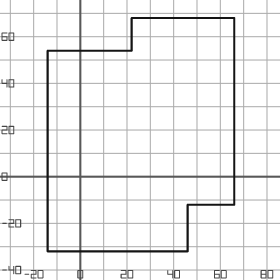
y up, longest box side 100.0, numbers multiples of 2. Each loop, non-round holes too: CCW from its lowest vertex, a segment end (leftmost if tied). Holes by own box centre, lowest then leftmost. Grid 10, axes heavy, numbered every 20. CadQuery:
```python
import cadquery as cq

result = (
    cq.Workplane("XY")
    .moveTo(-14.0, -32.0)
    .lineTo(46.0, -32.0)
    .lineTo(46.0, -12.0)
    .lineTo(66.0, -12.0)
    .lineTo(66.0, 68.0)
    .lineTo(22.0, 68.0)
    .lineTo(22.0, 54.0)
    .lineTo(-14.0, 54.0)
    .close()
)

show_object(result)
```